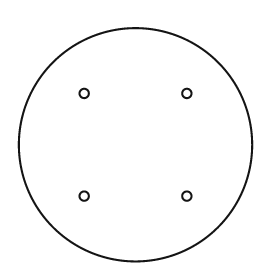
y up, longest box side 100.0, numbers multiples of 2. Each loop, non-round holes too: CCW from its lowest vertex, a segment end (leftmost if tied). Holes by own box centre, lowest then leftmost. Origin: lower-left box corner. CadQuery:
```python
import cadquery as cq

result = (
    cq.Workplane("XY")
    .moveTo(50.0, 50.0)
    .circle(50.0)
    .moveTo(28.0, 28.0)
    .circle(2.0)
    .moveTo(72.0, 28.0)
    .circle(2.0)
    .moveTo(28.0, 72.0)
    .circle(2.0)
    .moveTo(72.0, 72.0)
    .circle(2.0)
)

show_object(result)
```